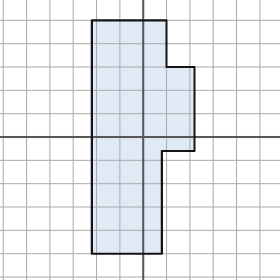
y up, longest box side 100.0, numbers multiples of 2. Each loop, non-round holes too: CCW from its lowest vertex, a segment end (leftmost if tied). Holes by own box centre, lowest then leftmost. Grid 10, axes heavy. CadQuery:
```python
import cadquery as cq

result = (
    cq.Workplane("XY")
    .moveTo(-22.0, -50.0)
    .lineTo(8.0, -50.0)
    .lineTo(8.0, -6.0)
    .lineTo(22.0, -6.0)
    .lineTo(22.0, 30.0)
    .lineTo(10.0, 30.0)
    .lineTo(10.0, 50.0)
    .lineTo(-22.0, 50.0)
    .close()
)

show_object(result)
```